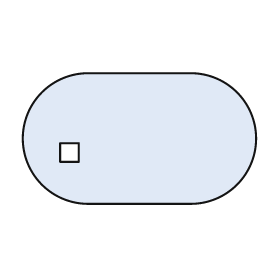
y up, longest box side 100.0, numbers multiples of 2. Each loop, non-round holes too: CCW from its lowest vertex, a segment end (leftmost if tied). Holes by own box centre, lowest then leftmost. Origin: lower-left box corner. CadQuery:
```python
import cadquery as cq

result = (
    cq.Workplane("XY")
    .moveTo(28.0, 0.0)
    .lineTo(72.0, 0.0)
    .threePointArc((100.0, 28.0), (72.0, 56.0))
    .lineTo(28.0, 56.0)
    .threePointArc((0.0, 28.0), (28.0, 0.0))
    .close()
    .moveTo(16.0, 18.0)
    .lineTo(24.0, 18.0)
    .lineTo(24.0, 26.0)
    .lineTo(16.0, 26.0)
    .close()
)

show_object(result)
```